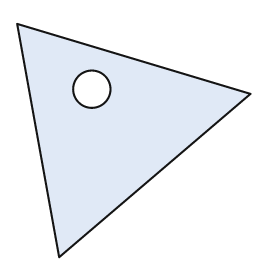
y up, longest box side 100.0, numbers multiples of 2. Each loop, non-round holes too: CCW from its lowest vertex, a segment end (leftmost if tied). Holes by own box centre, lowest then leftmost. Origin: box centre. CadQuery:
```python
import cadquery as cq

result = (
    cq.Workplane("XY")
    .moveTo(-32.0, -50.0)
    .lineTo(50.0, 20.0)
    .lineTo(-50.0, 50.0)
    .close()
    .moveTo(-18.0, 22.0)
    .circle(8.0)
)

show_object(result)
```